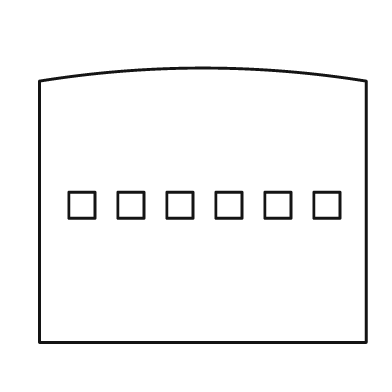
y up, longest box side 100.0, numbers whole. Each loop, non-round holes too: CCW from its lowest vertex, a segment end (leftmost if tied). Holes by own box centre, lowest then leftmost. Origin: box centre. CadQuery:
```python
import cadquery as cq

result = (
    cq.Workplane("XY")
    .moveTo(-50.0, -42.0)
    .lineTo(50.0, -42.0)
    .lineTo(50.0, 38.0)
    .threePointArc((0.0, 42.0), (-50.0, 38.0))
    .close()
    .moveTo(-41.0, -4.0)
    .lineTo(-33.0, -4.0)
    .lineTo(-33.0, 4.0)
    .lineTo(-41.0, 4.0)
    .close()
    .moveTo(-26.0, -4.0)
    .lineTo(-18.0, -4.0)
    .lineTo(-18.0, 4.0)
    .lineTo(-26.0, 4.0)
    .close()
    .moveTo(-11.0, -4.0)
    .lineTo(-3.0, -4.0)
    .lineTo(-3.0, 4.0)
    .lineTo(-11.0, 4.0)
    .close()
    .moveTo(4.0, -4.0)
    .lineTo(12.0, -4.0)
    .lineTo(12.0, 4.0)
    .lineTo(4.0, 4.0)
    .close()
    .moveTo(19.0, -4.0)
    .lineTo(27.0, -4.0)
    .lineTo(27.0, 4.0)
    .lineTo(19.0, 4.0)
    .close()
    .moveTo(34.0, -4.0)
    .lineTo(42.0, -4.0)
    .lineTo(42.0, 4.0)
    .lineTo(34.0, 4.0)
    .close()
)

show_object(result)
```